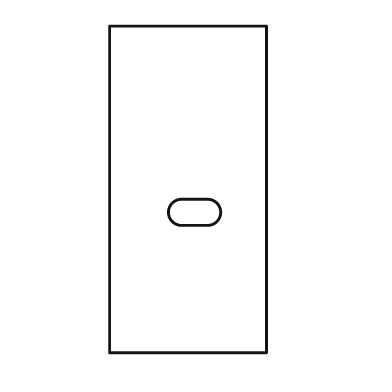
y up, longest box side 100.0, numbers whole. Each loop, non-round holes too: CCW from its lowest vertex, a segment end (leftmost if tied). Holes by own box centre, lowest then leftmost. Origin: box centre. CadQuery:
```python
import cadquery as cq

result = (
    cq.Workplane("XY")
    .moveTo(-24.0, -50.0)
    .lineTo(24.0, -50.0)
    .lineTo(24.0, 50.0)
    .lineTo(-24.0, 50.0)
    .close()
    .moveTo(-2.0, -11.0)
    .lineTo(6.0, -11.0)
    .threePointArc((10.0, -7.0), (6.0, -3.0))
    .lineTo(-2.0, -3.0)
    .threePointArc((-6.0, -7.0), (-2.0, -11.0))
    .close()
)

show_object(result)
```